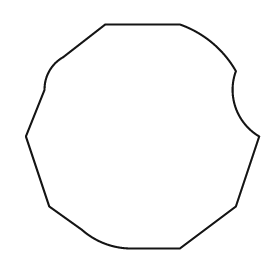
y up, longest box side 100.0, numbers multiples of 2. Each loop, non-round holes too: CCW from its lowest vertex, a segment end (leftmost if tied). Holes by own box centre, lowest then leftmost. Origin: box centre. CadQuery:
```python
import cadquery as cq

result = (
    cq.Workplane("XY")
    .moveTo(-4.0, -48.0)
    .lineTo(16.0, -48.0)
    .lineTo(40.0, -30.0)
    .lineTo(50.0, 0.0)
    .threePointArc((40.0, 12.0), (40.0, 28.0))
    .threePointArc((30.0, 40.0), (16.0, 48.0))
    .lineTo(-16.0, 48.0)
    .lineTo(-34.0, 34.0)
    .threePointArc((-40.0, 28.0), (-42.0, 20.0))
    .lineTo(-50.0, 0.0)
    .lineTo(-40.0, -30.0)
    .lineTo(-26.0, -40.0)
    .threePointArc((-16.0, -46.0), (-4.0, -48.0))
    .close()
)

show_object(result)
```